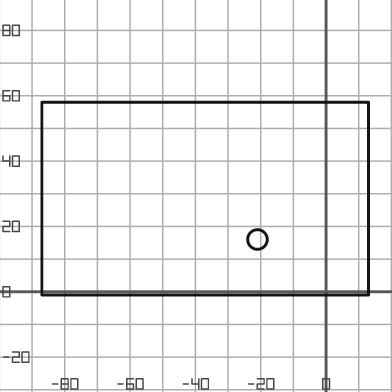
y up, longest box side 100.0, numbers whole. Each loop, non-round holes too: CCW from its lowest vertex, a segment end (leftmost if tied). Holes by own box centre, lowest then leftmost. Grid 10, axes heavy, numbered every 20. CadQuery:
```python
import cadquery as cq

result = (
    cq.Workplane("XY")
    .moveTo(-87.0, -1.0)
    .lineTo(13.0, -1.0)
    .lineTo(13.0, 58.0)
    .lineTo(-87.0, 58.0)
    .close()
    .moveTo(-21.0, 16.0)
    .circle(3.0)
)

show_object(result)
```